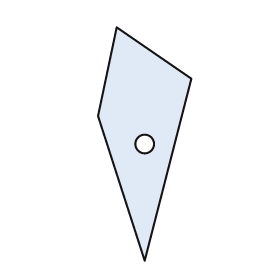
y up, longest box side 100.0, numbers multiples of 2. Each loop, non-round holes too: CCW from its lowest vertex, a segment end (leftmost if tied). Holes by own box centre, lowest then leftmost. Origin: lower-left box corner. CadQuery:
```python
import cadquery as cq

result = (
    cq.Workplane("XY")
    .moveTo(20.0, 0.0)
    .lineTo(40.0, 78.0)
    .lineTo(8.0, 100.0)
    .lineTo(0.0, 62.0)
    .close()
    .moveTo(20.0, 50.0)
    .circle(4.0)
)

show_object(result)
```